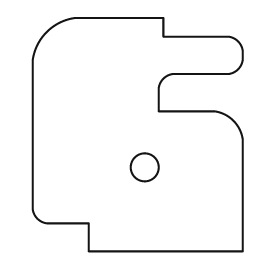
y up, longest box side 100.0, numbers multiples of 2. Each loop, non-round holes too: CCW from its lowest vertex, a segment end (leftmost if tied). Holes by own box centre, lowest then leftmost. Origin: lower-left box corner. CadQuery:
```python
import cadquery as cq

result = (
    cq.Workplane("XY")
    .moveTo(24.0, 0.0)
    .lineTo(90.0, 0.0)
    .lineTo(90.0, 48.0)
    .threePointArc((86.0, 56.0), (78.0, 60.0))
    .lineTo(54.0, 60.0)
    .lineTo(54.0, 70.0)
    .threePointArc((56.0, 74.0), (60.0, 76.0))
    .lineTo(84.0, 76.0)
    .threePointArc((88.0, 78.0), (90.0, 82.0))
    .lineTo(90.0, 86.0)
    .threePointArc((88.0, 90.0), (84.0, 92.0))
    .lineTo(56.0, 92.0)
    .lineTo(56.0, 100.0)
    .lineTo(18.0, 100.0)
    .threePointArc((6.0, 94.0), (0.0, 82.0))
    .lineTo(0.0, 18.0)
    .threePointArc((2.0, 14.0), (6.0, 12.0))
    .lineTo(24.0, 12.0)
    .close()
    .moveTo(48.0, 36.0)
    .circle(6.0)
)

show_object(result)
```